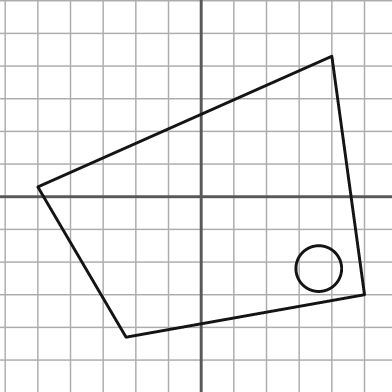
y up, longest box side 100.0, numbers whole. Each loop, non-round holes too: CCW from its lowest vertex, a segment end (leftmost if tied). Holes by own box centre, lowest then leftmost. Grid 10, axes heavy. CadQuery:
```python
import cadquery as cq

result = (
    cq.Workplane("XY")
    .moveTo(-23.0, -43.0)
    .lineTo(50.0, -30.0)
    .lineTo(40.0, 43.0)
    .lineTo(-50.0, 3.0)
    .close()
    .moveTo(36.0, -22.0)
    .circle(7.0)
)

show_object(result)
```